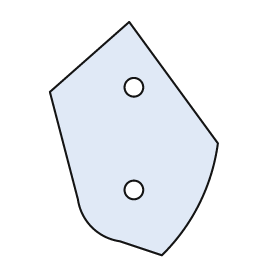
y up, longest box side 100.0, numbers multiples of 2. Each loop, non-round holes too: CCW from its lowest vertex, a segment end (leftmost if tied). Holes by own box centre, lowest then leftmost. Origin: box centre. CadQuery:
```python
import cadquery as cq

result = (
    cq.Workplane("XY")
    .moveTo(12.0, -50.0)
    .threePointArc((28.0, -28.0), (36.0, -2.0))
    .lineTo(-2.0, 50.0)
    .lineTo(-36.0, 20.0)
    .lineTo(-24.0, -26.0)
    .threePointArc((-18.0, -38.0), (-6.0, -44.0))
    .close()
    .moveTo(0.0, -22.0)
    .circle(4.0)
    .moveTo(0.0, 22.0)
    .circle(4.0)
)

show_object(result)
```